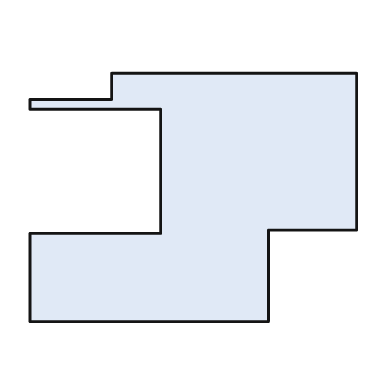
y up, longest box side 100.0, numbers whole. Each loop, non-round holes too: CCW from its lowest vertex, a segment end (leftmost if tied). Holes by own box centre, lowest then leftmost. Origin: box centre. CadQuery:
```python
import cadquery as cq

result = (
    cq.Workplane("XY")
    .moveTo(-50.0, -38.0)
    .lineTo(23.0, -38.0)
    .lineTo(23.0, -10.0)
    .lineTo(50.0, -10.0)
    .lineTo(50.0, 38.0)
    .lineTo(-25.0, 38.0)
    .lineTo(-25.0, 30.0)
    .lineTo(-50.0, 30.0)
    .lineTo(-50.0, 27.0)
    .lineTo(-10.0, 27.0)
    .lineTo(-10.0, -11.0)
    .lineTo(-50.0, -11.0)
    .close()
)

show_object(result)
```